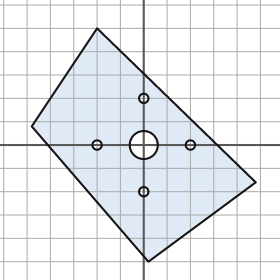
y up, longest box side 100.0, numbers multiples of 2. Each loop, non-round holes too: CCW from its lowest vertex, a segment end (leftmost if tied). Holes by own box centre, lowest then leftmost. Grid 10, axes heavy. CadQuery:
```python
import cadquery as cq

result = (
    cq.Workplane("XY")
    .moveTo(2.0, -50.0)
    .lineTo(48.0, -16.0)
    .lineTo(-20.0, 50.0)
    .lineTo(-48.0, 8.0)
    .close()
    .moveTo(0.0, -20.0)
    .circle(2.0)
    .moveTo(-20.0, 0.0)
    .circle(2.0)
    .moveTo(0.0, 0.0)
    .circle(6.0)
    .moveTo(20.0, 0.0)
    .circle(2.0)
    .moveTo(0.0, 20.0)
    .circle(2.0)
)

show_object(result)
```